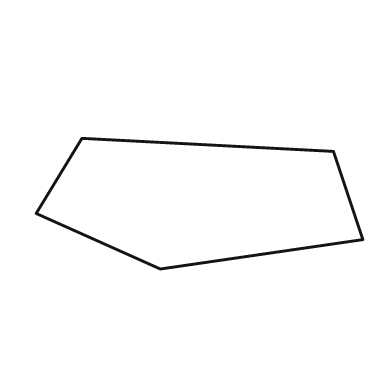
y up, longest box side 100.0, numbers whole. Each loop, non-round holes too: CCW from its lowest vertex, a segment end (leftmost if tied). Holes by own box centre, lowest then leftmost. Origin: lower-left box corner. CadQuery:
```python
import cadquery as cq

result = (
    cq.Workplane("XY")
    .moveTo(38.0, 0.0)
    .lineTo(100.0, 9.0)
    .lineTo(91.0, 36.0)
    .lineTo(14.0, 40.0)
    .lineTo(0.0, 17.0)
    .close()
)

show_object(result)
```